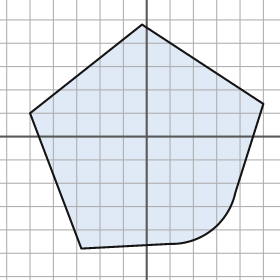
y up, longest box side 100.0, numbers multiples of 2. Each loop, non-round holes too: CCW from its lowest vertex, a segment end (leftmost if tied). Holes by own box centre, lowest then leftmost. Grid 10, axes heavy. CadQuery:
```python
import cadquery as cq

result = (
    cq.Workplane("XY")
    .moveTo(-28.0, -48.0)
    .lineTo(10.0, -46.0)
    .threePointArc((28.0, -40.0), (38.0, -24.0))
    .lineTo(50.0, 14.0)
    .lineTo(-2.0, 48.0)
    .lineTo(-50.0, 10.0)
    .close()
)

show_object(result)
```